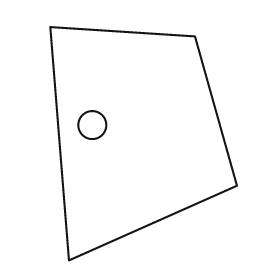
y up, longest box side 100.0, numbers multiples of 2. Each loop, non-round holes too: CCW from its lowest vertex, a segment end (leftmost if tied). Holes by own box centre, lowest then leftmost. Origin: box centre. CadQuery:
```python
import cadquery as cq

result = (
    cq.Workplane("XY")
    .moveTo(-32.0, -50.0)
    .lineTo(40.0, -18.0)
    .lineTo(22.0, 46.0)
    .lineTo(-40.0, 50.0)
    .close()
    .moveTo(-22.0, 8.0)
    .circle(6.0)
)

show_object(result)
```